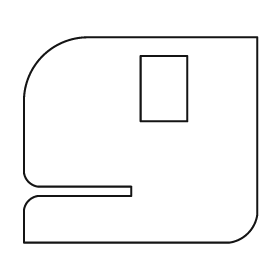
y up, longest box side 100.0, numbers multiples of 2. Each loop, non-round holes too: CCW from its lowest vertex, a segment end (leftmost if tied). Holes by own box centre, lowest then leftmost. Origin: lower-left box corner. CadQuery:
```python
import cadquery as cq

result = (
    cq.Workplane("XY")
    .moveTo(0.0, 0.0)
    .lineTo(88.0, 0.0)
    .threePointArc((96.0, 4.0), (100.0, 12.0))
    .lineTo(100.0, 88.0)
    .lineTo(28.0, 88.0)
    .threePointArc((8.0, 80.0), (0.0, 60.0))
    .lineTo(0.0, 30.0)
    .threePointArc((2.0, 26.0), (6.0, 24.0))
    .lineTo(46.0, 24.0)
    .lineTo(46.0, 20.0)
    .lineTo(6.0, 20.0)
    .threePointArc((2.0, 18.0), (0.0, 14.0))
    .close()
    .moveTo(50.0, 52.0)
    .lineTo(70.0, 52.0)
    .lineTo(70.0, 80.0)
    .lineTo(50.0, 80.0)
    .close()
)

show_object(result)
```